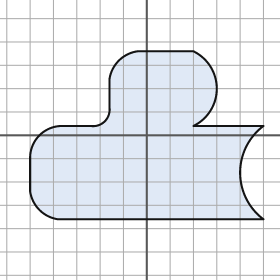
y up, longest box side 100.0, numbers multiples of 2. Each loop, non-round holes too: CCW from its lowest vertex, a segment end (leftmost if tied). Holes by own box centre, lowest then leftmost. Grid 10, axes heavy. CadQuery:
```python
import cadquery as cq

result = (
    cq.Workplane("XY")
    .moveTo(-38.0, -36.0)
    .lineTo(50.0, -36.0)
    .threePointArc((40.0, -16.0), (50.0, 4.0))
    .lineTo(20.0, 4.0)
    .threePointArc((30.0, 20.0), (20.0, 36.0))
    .lineTo(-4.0, 36.0)
    .threePointArc((-12.0, 32.0), (-16.0, 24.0))
    .lineTo(-16.0, 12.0)
    .threePointArc((-18.0, 6.0), (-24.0, 4.0))
    .lineTo(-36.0, 4.0)
    .threePointArc((-46.0, 0.0), (-50.0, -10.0))
    .lineTo(-50.0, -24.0)
    .threePointArc((-46.0, -32.0), (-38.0, -36.0))
    .close()
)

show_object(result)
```